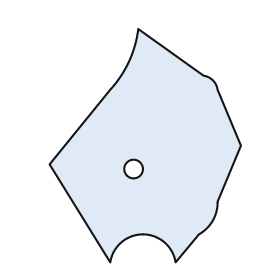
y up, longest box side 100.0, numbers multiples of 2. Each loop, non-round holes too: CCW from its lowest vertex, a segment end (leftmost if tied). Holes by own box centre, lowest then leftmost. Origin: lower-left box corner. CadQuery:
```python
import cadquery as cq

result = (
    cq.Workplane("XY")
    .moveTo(26.0, 0.0)
    .threePointArc((40.0, 12.0), (54.0, 0.0))
    .lineTo(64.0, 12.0)
    .threePointArc((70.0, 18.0), (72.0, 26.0))
    .lineTo(82.0, 50.0)
    .lineTo(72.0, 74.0)
    .threePointArc((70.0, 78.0), (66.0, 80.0))
    .lineTo(38.0, 100.0)
    .threePointArc((34.0, 86.0), (26.0, 74.0))
    .lineTo(0.0, 42.0)
    .close()
    .moveTo(36.0, 40.0)
    .circle(4.0)
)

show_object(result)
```